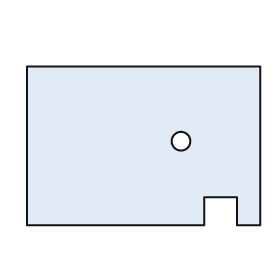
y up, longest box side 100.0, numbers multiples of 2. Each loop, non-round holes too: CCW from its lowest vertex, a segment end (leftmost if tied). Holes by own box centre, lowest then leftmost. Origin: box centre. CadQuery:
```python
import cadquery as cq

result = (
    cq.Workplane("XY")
    .moveTo(-50.0, -34.0)
    .lineTo(26.0, -34.0)
    .lineTo(26.0, -22.0)
    .lineTo(40.0, -22.0)
    .lineTo(40.0, -34.0)
    .lineTo(50.0, -34.0)
    .lineTo(50.0, 34.0)
    .lineTo(-50.0, 34.0)
    .close()
    .moveTo(16.0, 2.0)
    .circle(4.0)
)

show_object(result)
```